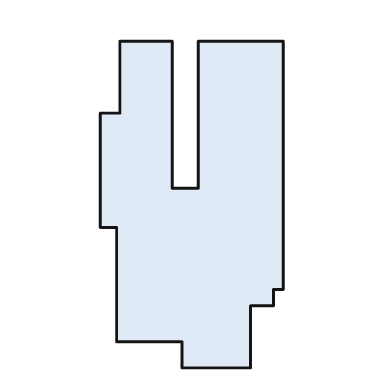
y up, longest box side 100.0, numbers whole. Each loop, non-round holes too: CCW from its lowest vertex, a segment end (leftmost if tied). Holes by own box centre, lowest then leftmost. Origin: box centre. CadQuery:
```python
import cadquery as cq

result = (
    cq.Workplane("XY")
    .moveTo(-3.0, -50.0)
    .lineTo(18.0, -50.0)
    .lineTo(18.0, -31.0)
    .lineTo(25.0, -31.0)
    .lineTo(25.0, -26.0)
    .lineTo(28.0, -26.0)
    .lineTo(28.0, 50.0)
    .lineTo(2.0, 50.0)
    .lineTo(2.0, 5.0)
    .lineTo(-6.0, 5.0)
    .lineTo(-6.0, 50.0)
    .lineTo(-22.0, 50.0)
    .lineTo(-22.0, 28.0)
    .lineTo(-28.0, 28.0)
    .lineTo(-28.0, -7.0)
    .lineTo(-23.0, -7.0)
    .lineTo(-23.0, -42.0)
    .lineTo(-3.0, -42.0)
    .close()
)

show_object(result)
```